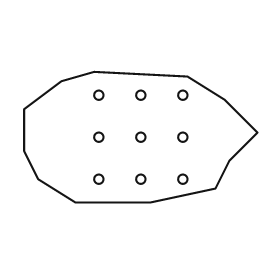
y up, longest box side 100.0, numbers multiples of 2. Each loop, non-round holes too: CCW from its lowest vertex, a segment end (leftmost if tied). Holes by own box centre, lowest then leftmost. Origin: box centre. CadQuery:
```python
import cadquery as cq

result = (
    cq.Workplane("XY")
    .moveTo(-28.0, -28.0)
    .lineTo(4.0, -28.0)
    .lineTo(32.0, -22.0)
    .lineTo(38.0, -10.0)
    .lineTo(50.0, 2.0)
    .lineTo(36.0, 16.0)
    .lineTo(20.0, 26.0)
    .lineTo(-20.0, 28.0)
    .lineTo(-34.0, 24.0)
    .lineTo(-50.0, 12.0)
    .lineTo(-50.0, -6.0)
    .lineTo(-44.0, -18.0)
    .close()
    .moveTo(-18.0, -18.0)
    .circle(2.0)
    .moveTo(0.0, -18.0)
    .circle(2.0)
    .moveTo(18.0, -18.0)
    .circle(2.0)
    .moveTo(-18.0, 0.0)
    .circle(2.0)
    .moveTo(0.0, 0.0)
    .circle(2.0)
    .moveTo(18.0, 0.0)
    .circle(2.0)
    .moveTo(-18.0, 18.0)
    .circle(2.0)
    .moveTo(0.0, 18.0)
    .circle(2.0)
    .moveTo(18.0, 18.0)
    .circle(2.0)
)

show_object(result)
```